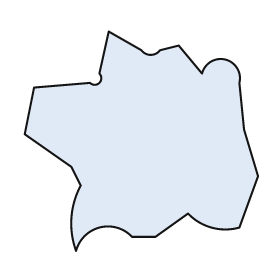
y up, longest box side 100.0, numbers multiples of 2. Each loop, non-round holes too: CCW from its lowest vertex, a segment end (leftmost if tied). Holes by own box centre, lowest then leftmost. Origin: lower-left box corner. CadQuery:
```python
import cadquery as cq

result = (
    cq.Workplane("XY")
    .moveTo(22.0, 0.0)
    .threePointArc((32.0, 10.0), (46.0, 6.0))
    .lineTo(56.0, 6.0)
    .lineTo(70.0, 16.0)
    .threePointArc((80.0, 10.0), (92.0, 10.0))
    .lineTo(100.0, 32.0)
    .lineTo(94.0, 52.0)
    .lineTo(92.0, 72.0)
    .threePointArc((86.0, 82.0), (76.0, 76.0))
    .lineTo(66.0, 88.0)
    .lineTo(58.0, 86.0)
    .threePointArc((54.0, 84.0), (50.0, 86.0))
    .lineTo(36.0, 94.0)
    .lineTo(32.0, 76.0)
    .threePointArc((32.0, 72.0), (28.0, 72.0))
    .lineTo(4.0, 70.0)
    .lineTo(0.0, 50.0)
    .lineTo(20.0, 36.0)
    .lineTo(24.0, 28.0)
    .threePointArc((20.0, 14.0), (22.0, 0.0))
    .close()
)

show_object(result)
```